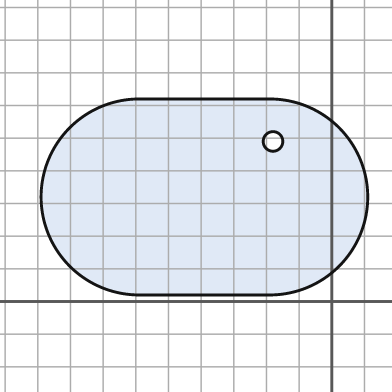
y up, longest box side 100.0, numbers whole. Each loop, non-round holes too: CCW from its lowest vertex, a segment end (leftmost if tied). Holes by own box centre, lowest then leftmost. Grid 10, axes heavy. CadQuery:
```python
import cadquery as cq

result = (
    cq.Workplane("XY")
    .moveTo(-59.0, 2.0)
    .lineTo(-19.0, 2.0)
    .threePointArc((11.0, 32.0), (-19.0, 62.0))
    .lineTo(-59.0, 62.0)
    .threePointArc((-89.0, 32.0), (-59.0, 2.0))
    .close()
    .moveTo(-18.0, 49.0)
    .circle(3.0)
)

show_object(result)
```